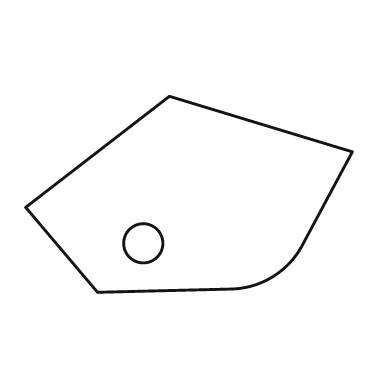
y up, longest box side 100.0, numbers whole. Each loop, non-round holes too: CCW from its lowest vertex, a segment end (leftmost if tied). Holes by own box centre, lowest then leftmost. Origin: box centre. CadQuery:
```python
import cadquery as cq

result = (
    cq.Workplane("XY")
    .moveTo(-28.0, -30.0)
    .lineTo(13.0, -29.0)
    .threePointArc((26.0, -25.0), (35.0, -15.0))
    .lineTo(50.0, 13.0)
    .lineTo(-6.0, 30.0)
    .lineTo(-50.0, -4.0)
    .close()
    .moveTo(-14.0, -15.0)
    .circle(6.0)
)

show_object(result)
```